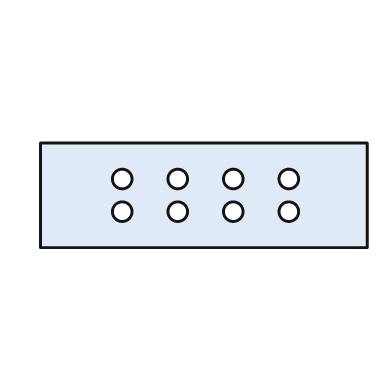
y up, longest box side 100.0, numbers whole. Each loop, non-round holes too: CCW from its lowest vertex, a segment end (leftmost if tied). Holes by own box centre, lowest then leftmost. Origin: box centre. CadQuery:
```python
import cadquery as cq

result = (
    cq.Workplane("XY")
    .moveTo(-50.0, -16.0)
    .lineTo(50.0, -16.0)
    .lineTo(50.0, 16.0)
    .lineTo(-50.0, 16.0)
    .close()
    .moveTo(-25.0, -5.0)
    .circle(3.0)
    .moveTo(-8.0, -5.0)
    .circle(3.0)
    .moveTo(9.0, -5.0)
    .circle(3.0)
    .moveTo(26.0, -5.0)
    .circle(3.0)
    .moveTo(-25.0, 5.0)
    .circle(3.0)
    .moveTo(-8.0, 5.0)
    .circle(3.0)
    .moveTo(9.0, 5.0)
    .circle(3.0)
    .moveTo(26.0, 5.0)
    .circle(3.0)
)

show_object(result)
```